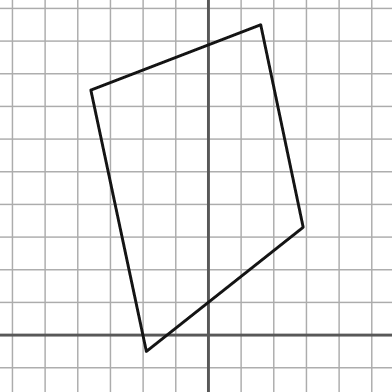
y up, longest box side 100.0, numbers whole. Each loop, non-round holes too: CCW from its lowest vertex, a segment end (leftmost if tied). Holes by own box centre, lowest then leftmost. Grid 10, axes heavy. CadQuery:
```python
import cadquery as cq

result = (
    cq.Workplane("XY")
    .moveTo(-19.0, -5.0)
    .lineTo(29.0, 33.0)
    .lineTo(16.0, 95.0)
    .lineTo(-36.0, 75.0)
    .close()
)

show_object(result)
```